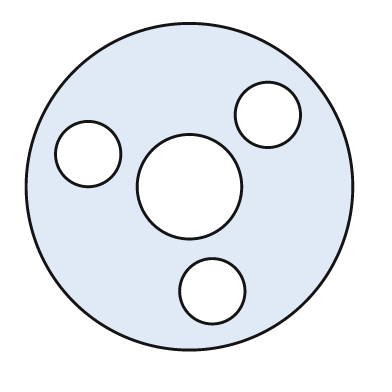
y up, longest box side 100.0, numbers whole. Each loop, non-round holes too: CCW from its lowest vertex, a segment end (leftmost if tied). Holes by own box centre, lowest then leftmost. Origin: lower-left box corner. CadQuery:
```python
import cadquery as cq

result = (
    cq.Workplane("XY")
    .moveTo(50.0, 50.0)
    .circle(50.0)
    .moveTo(57.0, 18.0)
    .circle(10.0)
    .moveTo(50.0, 50.0)
    .circle(16.0)
    .moveTo(19.0, 60.0)
    .circle(10.0)
    .moveTo(74.0, 72.0)
    .circle(10.0)
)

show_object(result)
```